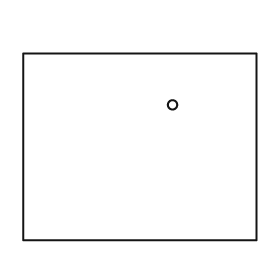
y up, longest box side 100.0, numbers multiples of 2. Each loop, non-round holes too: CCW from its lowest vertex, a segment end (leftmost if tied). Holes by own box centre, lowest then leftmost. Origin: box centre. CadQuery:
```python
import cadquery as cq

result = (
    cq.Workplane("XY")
    .moveTo(-50.0, -40.0)
    .lineTo(50.0, -40.0)
    .lineTo(50.0, 40.0)
    .lineTo(-50.0, 40.0)
    .close()
    .moveTo(14.0, 18.0)
    .circle(2.0)
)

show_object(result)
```